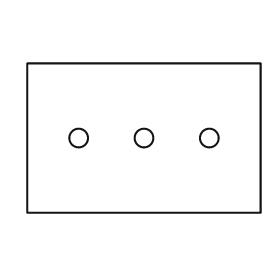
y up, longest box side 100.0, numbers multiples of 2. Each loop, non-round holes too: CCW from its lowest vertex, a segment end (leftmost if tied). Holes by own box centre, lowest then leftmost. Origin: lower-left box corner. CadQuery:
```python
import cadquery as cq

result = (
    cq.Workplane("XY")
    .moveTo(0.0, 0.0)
    .lineTo(100.0, 0.0)
    .lineTo(100.0, 64.0)
    .lineTo(0.0, 64.0)
    .close()
    .moveTo(22.0, 32.0)
    .circle(4.0)
    .moveTo(50.0, 32.0)
    .circle(4.0)
    .moveTo(78.0, 32.0)
    .circle(4.0)
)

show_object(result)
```